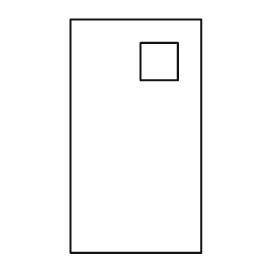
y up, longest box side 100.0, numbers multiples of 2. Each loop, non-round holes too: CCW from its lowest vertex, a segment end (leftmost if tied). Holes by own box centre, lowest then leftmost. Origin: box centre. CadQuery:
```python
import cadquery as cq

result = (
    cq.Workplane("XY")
    .moveTo(-28.0, -50.0)
    .lineTo(28.0, -50.0)
    .lineTo(28.0, 50.0)
    .lineTo(-28.0, 50.0)
    .close()
    .moveTo(2.0, 24.0)
    .lineTo(18.0, 24.0)
    .lineTo(18.0, 40.0)
    .lineTo(2.0, 40.0)
    .close()
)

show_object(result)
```